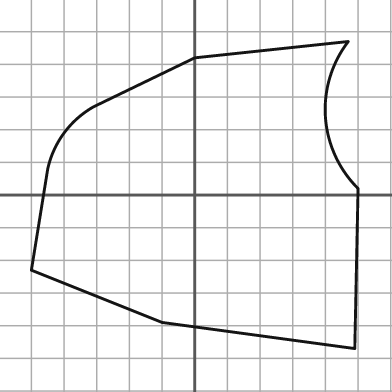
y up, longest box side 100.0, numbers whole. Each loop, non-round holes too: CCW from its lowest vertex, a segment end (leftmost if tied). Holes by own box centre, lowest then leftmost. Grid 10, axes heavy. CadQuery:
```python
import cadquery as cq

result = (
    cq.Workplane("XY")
    .moveTo(49.0, -47.0)
    .lineTo(50.0, 2.0)
    .threePointArc((40.0, 24.0), (47.0, 47.0))
    .lineTo(0.0, 42.0)
    .lineTo(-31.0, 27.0)
    .threePointArc((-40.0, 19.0), (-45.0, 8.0))
    .lineTo(-50.0, -23.0)
    .lineTo(-10.0, -39.0)
    .close()
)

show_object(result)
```